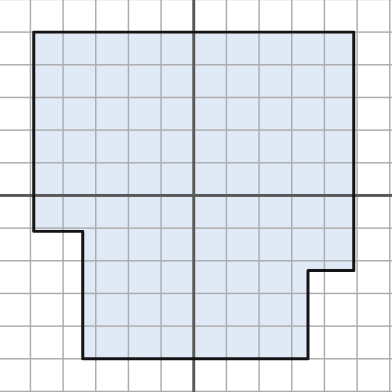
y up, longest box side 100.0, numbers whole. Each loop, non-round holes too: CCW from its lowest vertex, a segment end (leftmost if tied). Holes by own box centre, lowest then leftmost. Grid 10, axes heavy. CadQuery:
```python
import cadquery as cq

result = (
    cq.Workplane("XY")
    .moveTo(-34.0, -50.0)
    .lineTo(35.0, -50.0)
    .lineTo(35.0, -23.0)
    .lineTo(49.0, -23.0)
    .lineTo(49.0, 50.0)
    .lineTo(-49.0, 50.0)
    .lineTo(-49.0, -11.0)
    .lineTo(-34.0, -11.0)
    .close()
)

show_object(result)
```